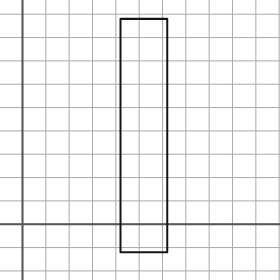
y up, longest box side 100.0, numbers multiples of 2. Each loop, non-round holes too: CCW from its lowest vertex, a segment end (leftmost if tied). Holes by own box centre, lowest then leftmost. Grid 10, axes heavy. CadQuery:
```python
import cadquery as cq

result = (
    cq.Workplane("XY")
    .moveTo(42.0, -12.0)
    .lineTo(62.0, -12.0)
    .lineTo(62.0, 88.0)
    .lineTo(42.0, 88.0)
    .close()
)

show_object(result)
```